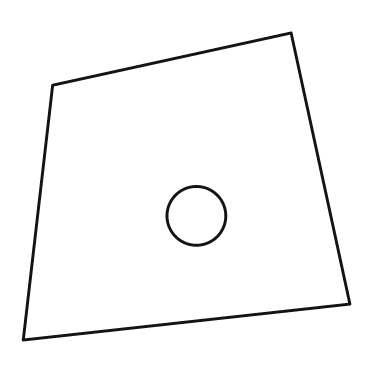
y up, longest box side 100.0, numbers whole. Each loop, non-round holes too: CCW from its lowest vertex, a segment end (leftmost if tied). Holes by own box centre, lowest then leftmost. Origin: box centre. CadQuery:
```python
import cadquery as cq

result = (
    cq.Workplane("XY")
    .moveTo(-50.0, -47.0)
    .lineTo(50.0, -36.0)
    .lineTo(32.0, 47.0)
    .lineTo(-41.0, 31.0)
    .close()
    .moveTo(3.0, -9.0)
    .circle(9.0)
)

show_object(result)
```